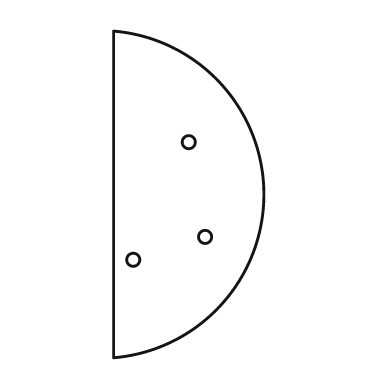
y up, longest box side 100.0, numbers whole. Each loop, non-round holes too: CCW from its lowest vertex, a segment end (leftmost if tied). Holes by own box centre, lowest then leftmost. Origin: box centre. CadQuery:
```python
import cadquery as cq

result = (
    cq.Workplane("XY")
    .moveTo(-23.0, -50.0)
    .threePointArc((23.0, 0.0), (-23.0, 50.0))
    .close()
    .moveTo(-17.0, -20.0)
    .circle(2.0)
    .moveTo(5.0, -13.0)
    .circle(2.0)
    .moveTo(0.0, 16.0)
    .circle(2.0)
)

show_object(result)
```